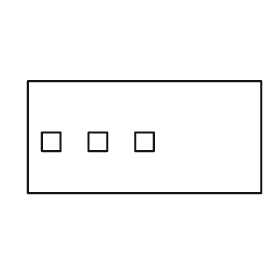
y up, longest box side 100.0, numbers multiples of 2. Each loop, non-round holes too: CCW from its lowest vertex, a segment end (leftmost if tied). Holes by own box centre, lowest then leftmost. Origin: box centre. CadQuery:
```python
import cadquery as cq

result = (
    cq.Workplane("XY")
    .moveTo(-50.0, -24.0)
    .lineTo(50.0, -24.0)
    .lineTo(50.0, 24.0)
    .lineTo(-50.0, 24.0)
    .close()
    .moveTo(-44.0, -6.0)
    .lineTo(-36.0, -6.0)
    .lineTo(-36.0, 2.0)
    .lineTo(-44.0, 2.0)
    .close()
    .moveTo(-24.0, -6.0)
    .lineTo(-16.0, -6.0)
    .lineTo(-16.0, 2.0)
    .lineTo(-24.0, 2.0)
    .close()
    .moveTo(-4.0, -6.0)
    .lineTo(4.0, -6.0)
    .lineTo(4.0, 2.0)
    .lineTo(-4.0, 2.0)
    .close()
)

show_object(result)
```